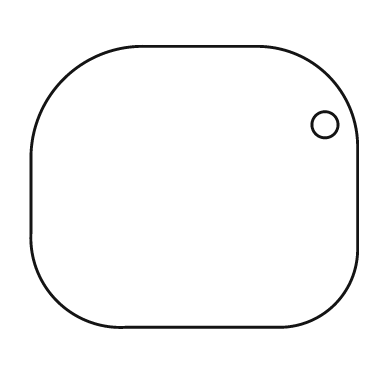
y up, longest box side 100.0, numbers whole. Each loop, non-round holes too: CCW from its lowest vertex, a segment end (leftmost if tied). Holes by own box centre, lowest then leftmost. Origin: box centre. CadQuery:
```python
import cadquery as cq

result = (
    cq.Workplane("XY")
    .moveTo(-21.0, -43.0)
    .lineTo(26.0, -43.0)
    .threePointArc((43.0, -36.0), (50.0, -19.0))
    .lineTo(50.0, 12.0)
    .threePointArc((41.0, 34.0), (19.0, 43.0))
    .lineTo(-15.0, 43.0)
    .threePointArc((-40.0, 33.0), (-50.0, 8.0))
    .lineTo(-50.0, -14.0)
    .threePointArc((-42.0, -35.0), (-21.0, -43.0))
    .close()
    .moveTo(40.0, 19.0)
    .circle(4.0)
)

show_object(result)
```